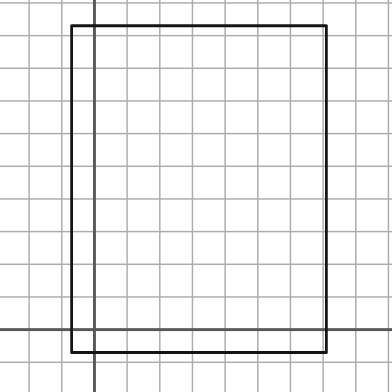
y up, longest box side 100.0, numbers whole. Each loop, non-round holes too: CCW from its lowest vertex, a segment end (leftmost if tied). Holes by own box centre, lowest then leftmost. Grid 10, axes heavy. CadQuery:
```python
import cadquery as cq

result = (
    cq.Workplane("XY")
    .moveTo(-7.0, -7.0)
    .lineTo(71.0, -7.0)
    .lineTo(71.0, 93.0)
    .lineTo(-7.0, 93.0)
    .close()
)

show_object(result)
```